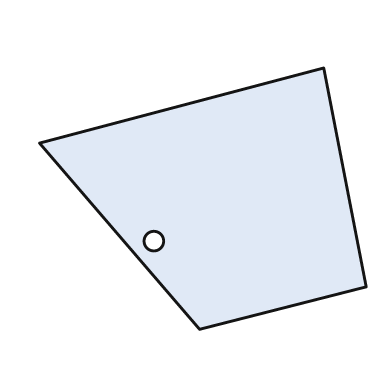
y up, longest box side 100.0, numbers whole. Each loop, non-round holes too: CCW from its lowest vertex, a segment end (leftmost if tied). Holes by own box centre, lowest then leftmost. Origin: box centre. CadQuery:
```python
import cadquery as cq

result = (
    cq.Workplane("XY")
    .moveTo(-1.0, -40.0)
    .lineTo(50.0, -27.0)
    .lineTo(37.0, 40.0)
    .lineTo(-50.0, 17.0)
    .close()
    .moveTo(-15.0, -13.0)
    .circle(3.0)
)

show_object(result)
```